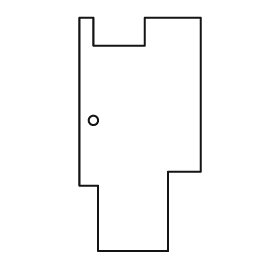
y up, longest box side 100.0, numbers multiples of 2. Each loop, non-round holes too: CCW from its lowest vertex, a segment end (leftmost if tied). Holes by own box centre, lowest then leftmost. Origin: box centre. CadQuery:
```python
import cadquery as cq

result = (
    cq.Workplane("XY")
    .moveTo(-18.0, -50.0)
    .lineTo(12.0, -50.0)
    .lineTo(12.0, -16.0)
    .lineTo(26.0, -16.0)
    .lineTo(26.0, 50.0)
    .lineTo(2.0, 50.0)
    .lineTo(2.0, 38.0)
    .lineTo(-20.0, 38.0)
    .lineTo(-20.0, 50.0)
    .lineTo(-26.0, 50.0)
    .lineTo(-26.0, -22.0)
    .lineTo(-18.0, -22.0)
    .close()
    .moveTo(-20.0, 6.0)
    .circle(2.0)
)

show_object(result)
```